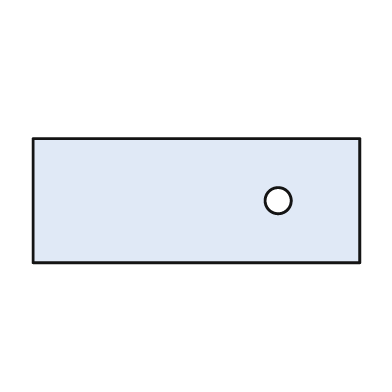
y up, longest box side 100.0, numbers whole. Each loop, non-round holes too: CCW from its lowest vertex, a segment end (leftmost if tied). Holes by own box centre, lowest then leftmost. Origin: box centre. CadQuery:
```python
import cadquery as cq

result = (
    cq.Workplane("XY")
    .moveTo(-50.0, -19.0)
    .lineTo(50.0, -19.0)
    .lineTo(50.0, 19.0)
    .lineTo(-50.0, 19.0)
    .close()
    .moveTo(25.0, 0.0)
    .circle(4.0)
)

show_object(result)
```